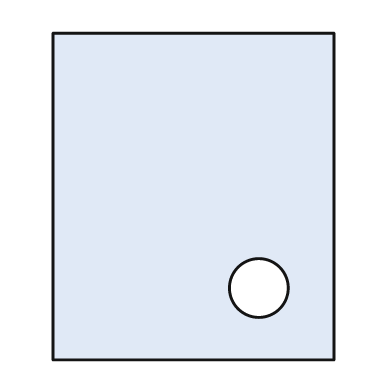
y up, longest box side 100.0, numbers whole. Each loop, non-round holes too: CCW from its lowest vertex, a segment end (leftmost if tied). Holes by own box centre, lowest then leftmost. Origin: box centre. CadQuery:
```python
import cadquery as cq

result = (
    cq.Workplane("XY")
    .moveTo(-43.0, -50.0)
    .lineTo(43.0, -50.0)
    .lineTo(43.0, 50.0)
    .lineTo(-43.0, 50.0)
    .close()
    .moveTo(20.0, -28.0)
    .circle(9.0)
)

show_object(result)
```